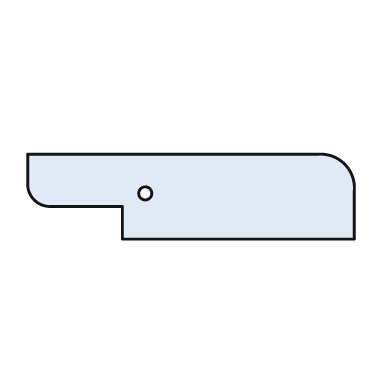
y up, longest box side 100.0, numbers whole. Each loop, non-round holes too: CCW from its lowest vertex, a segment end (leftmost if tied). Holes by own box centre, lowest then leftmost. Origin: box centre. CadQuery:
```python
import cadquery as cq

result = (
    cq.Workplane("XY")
    .moveTo(-21.0, -13.0)
    .lineTo(50.0, -13.0)
    .lineTo(50.0, 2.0)
    .threePointArc((47.0, 10.0), (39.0, 13.0))
    .lineTo(-50.0, 13.0)
    .lineTo(-50.0, 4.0)
    .threePointArc((-48.0, -1.0), (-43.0, -3.0))
    .lineTo(-21.0, -3.0)
    .close()
    .moveTo(-14.0, 1.0)
    .circle(2.0)
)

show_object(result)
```